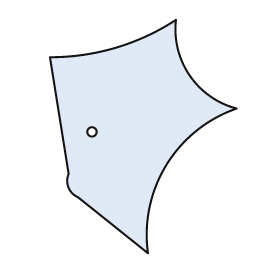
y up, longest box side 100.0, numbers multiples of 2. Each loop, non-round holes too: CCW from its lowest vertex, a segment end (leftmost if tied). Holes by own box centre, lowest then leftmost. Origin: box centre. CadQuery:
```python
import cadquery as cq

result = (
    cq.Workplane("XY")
    .moveTo(2.0, -50.0)
    .threePointArc((10.0, -12.0), (40.0, 12.0))
    .threePointArc((20.0, 26.0), (14.0, 50.0))
    .threePointArc((-12.0, 38.0), (-40.0, 34.0))
    .lineTo(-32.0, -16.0)
    .threePointArc((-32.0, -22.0), (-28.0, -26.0))
    .close()
    .moveTo(-22.0, 2.0)
    .circle(2.0)
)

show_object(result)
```